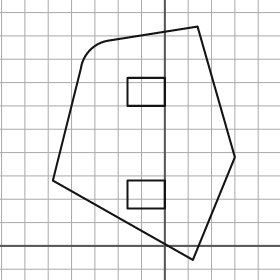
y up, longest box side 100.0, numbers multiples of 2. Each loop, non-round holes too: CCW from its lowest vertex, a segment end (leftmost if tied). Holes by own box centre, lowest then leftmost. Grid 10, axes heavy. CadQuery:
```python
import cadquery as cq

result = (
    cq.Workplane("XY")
    .moveTo(12.0, -6.0)
    .lineTo(30.0, 38.0)
    .lineTo(14.0, 94.0)
    .lineTo(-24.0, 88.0)
    .threePointArc((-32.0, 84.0), (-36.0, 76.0))
    .lineTo(-48.0, 28.0)
    .close()
    .moveTo(-16.0, 16.0)
    .lineTo(0.0, 16.0)
    .lineTo(0.0, 28.0)
    .lineTo(-16.0, 28.0)
    .close()
    .moveTo(-16.0, 60.0)
    .lineTo(0.0, 60.0)
    .lineTo(0.0, 72.0)
    .lineTo(-16.0, 72.0)
    .close()
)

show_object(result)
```